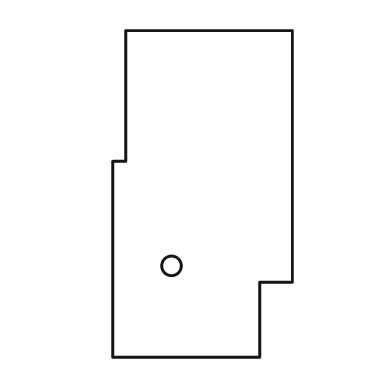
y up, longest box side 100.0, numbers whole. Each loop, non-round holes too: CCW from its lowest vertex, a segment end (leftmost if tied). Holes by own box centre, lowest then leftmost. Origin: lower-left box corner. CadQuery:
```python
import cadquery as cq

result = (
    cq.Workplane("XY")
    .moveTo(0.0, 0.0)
    .lineTo(45.0, 0.0)
    .lineTo(45.0, 23.0)
    .lineTo(55.0, 23.0)
    .lineTo(55.0, 100.0)
    .lineTo(4.0, 100.0)
    .lineTo(4.0, 60.0)
    .lineTo(0.0, 60.0)
    .close()
    .moveTo(18.0, 28.0)
    .circle(3.0)
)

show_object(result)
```